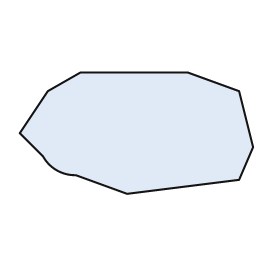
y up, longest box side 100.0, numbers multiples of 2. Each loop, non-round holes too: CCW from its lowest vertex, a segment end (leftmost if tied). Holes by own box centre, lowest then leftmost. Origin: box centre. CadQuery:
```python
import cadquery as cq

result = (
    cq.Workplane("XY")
    .moveTo(-4.0, -26.0)
    .lineTo(44.0, -20.0)
    .lineTo(50.0, -6.0)
    .lineTo(44.0, 18.0)
    .lineTo(22.0, 26.0)
    .lineTo(-24.0, 26.0)
    .lineTo(-38.0, 18.0)
    .lineTo(-50.0, 0.0)
    .lineTo(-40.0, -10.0)
    .threePointArc((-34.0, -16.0), (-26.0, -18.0))
    .close()
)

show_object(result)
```